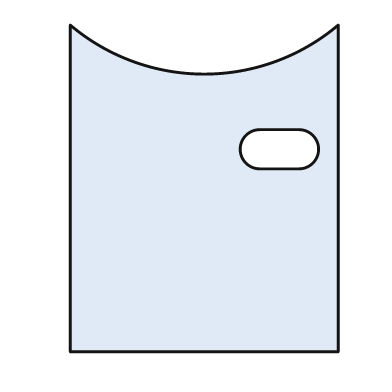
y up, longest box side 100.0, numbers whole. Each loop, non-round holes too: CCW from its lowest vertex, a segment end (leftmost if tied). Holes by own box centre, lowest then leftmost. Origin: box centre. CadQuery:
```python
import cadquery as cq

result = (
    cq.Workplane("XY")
    .moveTo(-41.0, -50.0)
    .lineTo(41.0, -50.0)
    .lineTo(41.0, 50.0)
    .threePointArc((0.0, 35.0), (-41.0, 50.0))
    .close()
    .moveTo(17.0, 6.0)
    .lineTo(29.0, 6.0)
    .threePointArc((35.0, 12.0), (29.0, 18.0))
    .lineTo(17.0, 18.0)
    .threePointArc((11.0, 12.0), (17.0, 6.0))
    .close()
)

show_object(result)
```